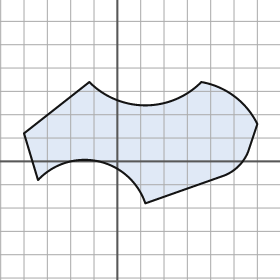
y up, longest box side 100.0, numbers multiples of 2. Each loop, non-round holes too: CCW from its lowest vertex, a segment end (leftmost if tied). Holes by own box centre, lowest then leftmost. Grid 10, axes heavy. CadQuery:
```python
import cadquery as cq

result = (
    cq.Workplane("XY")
    .moveTo(12.0, -18.0)
    .lineTo(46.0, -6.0)
    .threePointArc((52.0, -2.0), (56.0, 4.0))
    .lineTo(60.0, 16.0)
    .threePointArc((50.0, 28.0), (36.0, 34.0))
    .threePointArc((12.0, 24.0), (-12.0, 34.0))
    .lineTo(-40.0, 12.0)
    .lineTo(-34.0, -8.0)
    .threePointArc((-8.0, 0.0), (12.0, -18.0))
    .close()
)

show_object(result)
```